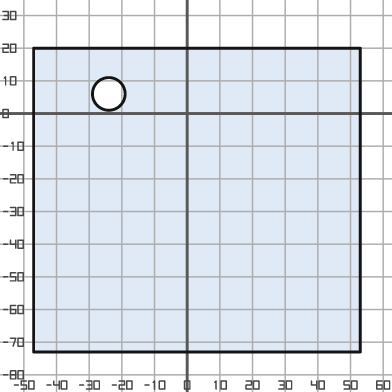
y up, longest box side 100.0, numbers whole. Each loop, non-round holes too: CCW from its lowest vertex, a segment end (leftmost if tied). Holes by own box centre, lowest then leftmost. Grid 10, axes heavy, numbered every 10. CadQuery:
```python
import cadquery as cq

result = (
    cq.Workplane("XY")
    .moveTo(-47.0, -73.0)
    .lineTo(53.0, -73.0)
    .lineTo(53.0, 20.0)
    .lineTo(-47.0, 20.0)
    .close()
    .moveTo(-24.0, 6.0)
    .circle(5.0)
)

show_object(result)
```